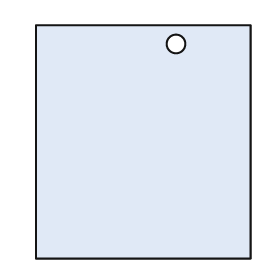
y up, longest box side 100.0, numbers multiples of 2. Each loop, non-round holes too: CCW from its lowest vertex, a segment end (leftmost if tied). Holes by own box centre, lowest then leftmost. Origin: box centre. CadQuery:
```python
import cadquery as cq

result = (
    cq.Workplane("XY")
    .moveTo(-46.0, -50.0)
    .lineTo(46.0, -50.0)
    .lineTo(46.0, 50.0)
    .lineTo(-46.0, 50.0)
    .close()
    .moveTo(14.0, 42.0)
    .circle(4.0)
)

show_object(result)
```